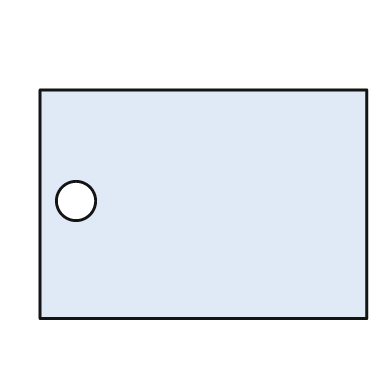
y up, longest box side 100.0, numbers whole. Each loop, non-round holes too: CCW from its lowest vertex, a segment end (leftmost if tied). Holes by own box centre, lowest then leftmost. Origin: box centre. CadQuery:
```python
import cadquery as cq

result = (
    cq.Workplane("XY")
    .moveTo(-50.0, -35.0)
    .lineTo(50.0, -35.0)
    .lineTo(50.0, 35.0)
    .lineTo(-50.0, 35.0)
    .close()
    .moveTo(-39.0, 1.0)
    .circle(6.0)
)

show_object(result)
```